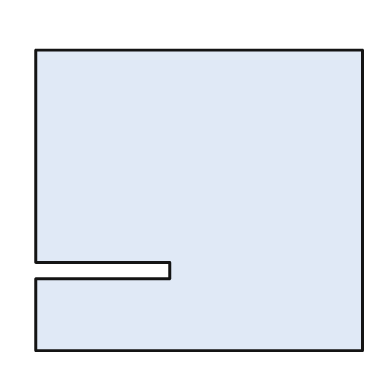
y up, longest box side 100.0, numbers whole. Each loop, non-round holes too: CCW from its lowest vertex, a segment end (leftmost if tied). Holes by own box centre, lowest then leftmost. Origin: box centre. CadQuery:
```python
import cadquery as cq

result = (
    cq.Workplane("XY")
    .moveTo(-50.0, -46.0)
    .lineTo(50.0, -46.0)
    .lineTo(50.0, 46.0)
    .lineTo(-50.0, 46.0)
    .lineTo(-50.0, -19.0)
    .lineTo(-9.0, -19.0)
    .lineTo(-9.0, -24.0)
    .lineTo(-50.0, -24.0)
    .close()
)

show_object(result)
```